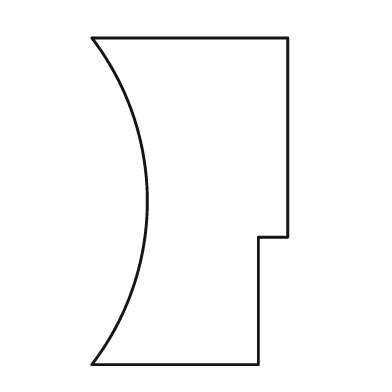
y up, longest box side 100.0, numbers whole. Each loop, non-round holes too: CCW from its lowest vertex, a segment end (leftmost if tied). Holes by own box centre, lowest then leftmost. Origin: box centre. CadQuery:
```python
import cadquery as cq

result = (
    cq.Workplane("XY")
    .moveTo(-30.0, -50.0)
    .lineTo(21.0, -50.0)
    .lineTo(21.0, -11.0)
    .lineTo(30.0, -11.0)
    .lineTo(30.0, 50.0)
    .lineTo(-30.0, 50.0)
    .threePointArc((-13.0, 0.0), (-30.0, -50.0))
    .close()
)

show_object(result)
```